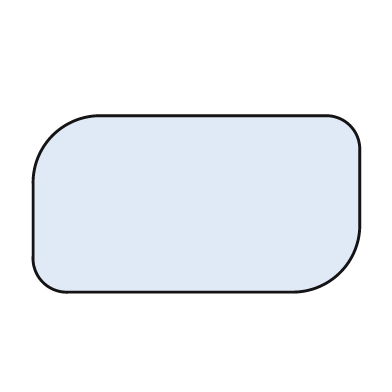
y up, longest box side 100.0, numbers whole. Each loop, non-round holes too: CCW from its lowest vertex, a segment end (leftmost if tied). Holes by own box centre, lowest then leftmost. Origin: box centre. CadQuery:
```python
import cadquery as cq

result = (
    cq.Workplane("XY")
    .moveTo(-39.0, -27.0)
    .lineTo(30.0, -27.0)
    .threePointArc((44.0, -21.0), (50.0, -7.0))
    .lineTo(50.0, 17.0)
    .threePointArc((47.0, 24.0), (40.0, 27.0))
    .lineTo(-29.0, 27.0)
    .threePointArc((-44.0, 21.0), (-50.0, 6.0))
    .lineTo(-50.0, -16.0)
    .threePointArc((-47.0, -24.0), (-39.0, -27.0))
    .close()
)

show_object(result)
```